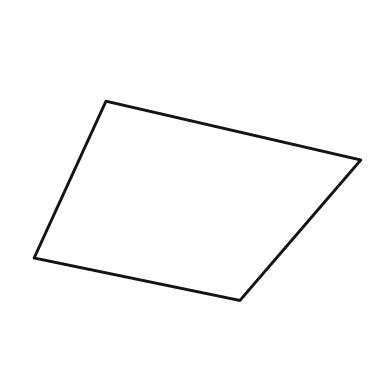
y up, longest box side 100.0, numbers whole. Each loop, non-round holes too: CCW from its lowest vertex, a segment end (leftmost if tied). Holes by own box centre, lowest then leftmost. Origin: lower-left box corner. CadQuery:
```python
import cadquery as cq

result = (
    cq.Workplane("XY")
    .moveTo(63.0, 0.0)
    .lineTo(100.0, 43.0)
    .lineTo(22.0, 61.0)
    .lineTo(0.0, 13.0)
    .close()
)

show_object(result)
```